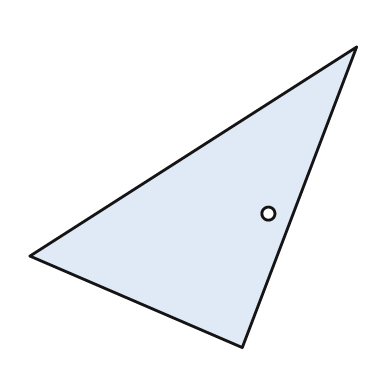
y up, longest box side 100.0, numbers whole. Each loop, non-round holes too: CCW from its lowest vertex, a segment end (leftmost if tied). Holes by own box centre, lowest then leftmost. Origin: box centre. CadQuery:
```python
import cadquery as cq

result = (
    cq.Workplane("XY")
    .moveTo(15.0, -46.0)
    .lineTo(50.0, 46.0)
    .lineTo(-50.0, -18.0)
    .close()
    .moveTo(23.0, -5.0)
    .circle(2.0)
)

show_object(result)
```